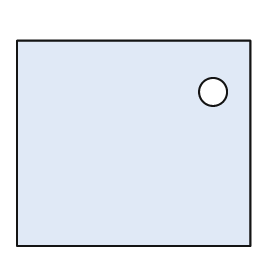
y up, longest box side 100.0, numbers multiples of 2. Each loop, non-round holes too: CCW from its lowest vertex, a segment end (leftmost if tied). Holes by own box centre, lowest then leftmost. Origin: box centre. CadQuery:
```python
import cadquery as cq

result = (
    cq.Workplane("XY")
    .moveTo(-50.0, -44.0)
    .lineTo(50.0, -44.0)
    .lineTo(50.0, 44.0)
    .lineTo(-50.0, 44.0)
    .close()
    .moveTo(34.0, 22.0)
    .circle(6.0)
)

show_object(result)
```